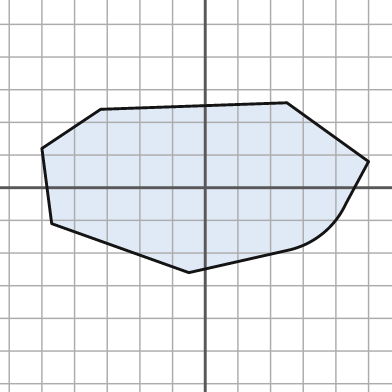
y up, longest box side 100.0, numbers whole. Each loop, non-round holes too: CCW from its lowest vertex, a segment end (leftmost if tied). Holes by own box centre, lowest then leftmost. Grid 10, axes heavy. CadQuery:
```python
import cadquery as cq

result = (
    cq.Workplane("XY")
    .moveTo(-5.0, -26.0)
    .lineTo(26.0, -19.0)
    .threePointArc((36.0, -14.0), (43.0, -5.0))
    .lineTo(50.0, 8.0)
    .lineTo(25.0, 26.0)
    .lineTo(-32.0, 24.0)
    .lineTo(-50.0, 12.0)
    .lineTo(-47.0, -11.0)
    .close()
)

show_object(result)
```